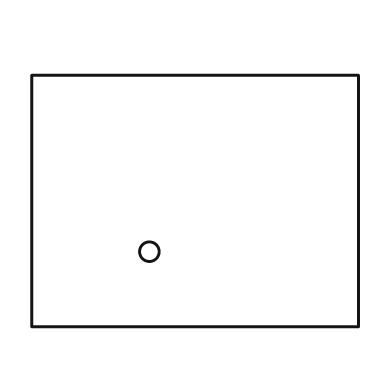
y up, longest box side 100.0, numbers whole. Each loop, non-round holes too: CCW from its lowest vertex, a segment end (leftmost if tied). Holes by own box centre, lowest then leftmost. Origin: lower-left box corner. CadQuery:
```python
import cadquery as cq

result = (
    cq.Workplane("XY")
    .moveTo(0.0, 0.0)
    .lineTo(100.0, 0.0)
    .lineTo(100.0, 77.0)
    .lineTo(0.0, 77.0)
    .close()
    .moveTo(36.0, 23.0)
    .circle(3.0)
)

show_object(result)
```